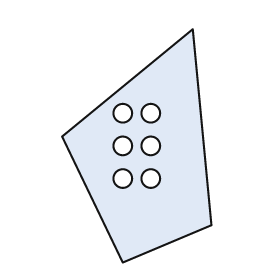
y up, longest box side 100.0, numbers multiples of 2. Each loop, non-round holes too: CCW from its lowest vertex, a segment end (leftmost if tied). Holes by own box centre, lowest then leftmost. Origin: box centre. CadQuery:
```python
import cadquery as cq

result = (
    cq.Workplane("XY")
    .moveTo(-6.0, -50.0)
    .lineTo(32.0, -34.0)
    .lineTo(24.0, 50.0)
    .lineTo(-32.0, 4.0)
    .close()
    .moveTo(-6.0, -14.0)
    .circle(4.0)
    .moveTo(6.0, -14.0)
    .circle(4.0)
    .moveTo(-6.0, 0.0)
    .circle(4.0)
    .moveTo(6.0, 0.0)
    .circle(4.0)
    .moveTo(-6.0, 14.0)
    .circle(4.0)
    .moveTo(6.0, 14.0)
    .circle(4.0)
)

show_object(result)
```